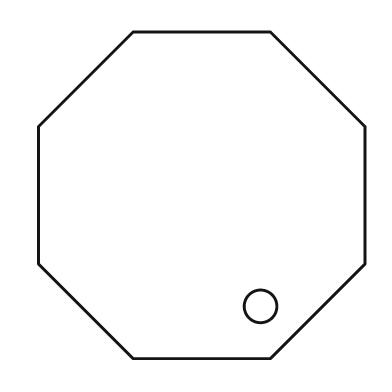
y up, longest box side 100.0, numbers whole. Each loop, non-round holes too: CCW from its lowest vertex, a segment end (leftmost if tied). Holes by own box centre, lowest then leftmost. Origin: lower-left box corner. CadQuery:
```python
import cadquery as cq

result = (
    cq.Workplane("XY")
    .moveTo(29.0, 0.0)
    .lineTo(71.0, 0.0)
    .lineTo(100.0, 29.0)
    .lineTo(100.0, 71.0)
    .lineTo(71.0, 100.0)
    .lineTo(29.0, 100.0)
    .lineTo(0.0, 71.0)
    .lineTo(0.0, 29.0)
    .close()
    .moveTo(68.0, 16.0)
    .circle(5.0)
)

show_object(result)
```